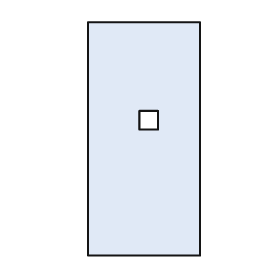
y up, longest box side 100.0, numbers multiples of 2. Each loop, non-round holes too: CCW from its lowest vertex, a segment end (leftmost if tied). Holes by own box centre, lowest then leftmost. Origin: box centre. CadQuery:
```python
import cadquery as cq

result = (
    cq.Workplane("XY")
    .moveTo(-24.0, -50.0)
    .lineTo(24.0, -50.0)
    .lineTo(24.0, 50.0)
    .lineTo(-24.0, 50.0)
    .close()
    .moveTo(-2.0, 4.0)
    .lineTo(6.0, 4.0)
    .lineTo(6.0, 12.0)
    .lineTo(-2.0, 12.0)
    .close()
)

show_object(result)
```